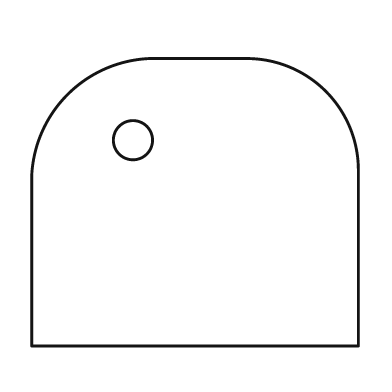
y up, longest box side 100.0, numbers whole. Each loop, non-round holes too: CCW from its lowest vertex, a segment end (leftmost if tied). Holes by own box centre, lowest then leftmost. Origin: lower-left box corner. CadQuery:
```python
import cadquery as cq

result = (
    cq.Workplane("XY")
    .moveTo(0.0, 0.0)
    .lineTo(100.0, 0.0)
    .lineTo(100.0, 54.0)
    .threePointArc((90.0, 78.0), (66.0, 88.0))
    .lineTo(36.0, 88.0)
    .threePointArc((11.0, 77.0), (0.0, 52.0))
    .close()
    .moveTo(31.0, 63.0)
    .circle(6.0)
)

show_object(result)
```